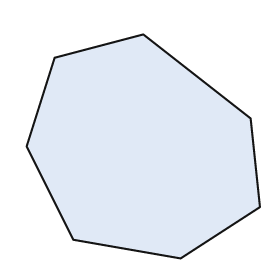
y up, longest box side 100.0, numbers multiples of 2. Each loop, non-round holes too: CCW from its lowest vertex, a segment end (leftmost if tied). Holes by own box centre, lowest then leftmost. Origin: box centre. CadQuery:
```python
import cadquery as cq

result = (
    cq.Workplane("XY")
    .moveTo(16.0, -48.0)
    .lineTo(50.0, -26.0)
    .lineTo(46.0, 12.0)
    .lineTo(0.0, 48.0)
    .lineTo(-38.0, 38.0)
    .lineTo(-50.0, 0.0)
    .lineTo(-30.0, -40.0)
    .close()
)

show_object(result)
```